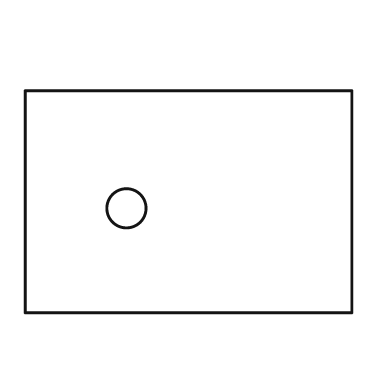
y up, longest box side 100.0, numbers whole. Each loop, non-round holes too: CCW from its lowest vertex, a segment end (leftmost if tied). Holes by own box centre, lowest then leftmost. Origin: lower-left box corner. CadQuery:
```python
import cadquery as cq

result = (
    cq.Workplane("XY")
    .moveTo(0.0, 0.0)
    .lineTo(100.0, 0.0)
    .lineTo(100.0, 68.0)
    .lineTo(0.0, 68.0)
    .close()
    .moveTo(31.0, 32.0)
    .circle(6.0)
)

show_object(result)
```